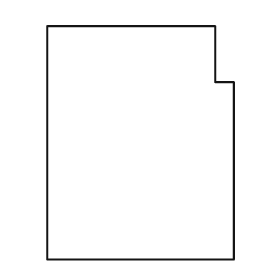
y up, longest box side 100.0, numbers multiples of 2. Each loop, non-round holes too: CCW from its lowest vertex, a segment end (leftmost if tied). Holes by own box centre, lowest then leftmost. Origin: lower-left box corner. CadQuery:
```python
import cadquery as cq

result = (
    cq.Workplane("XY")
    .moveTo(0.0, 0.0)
    .lineTo(80.0, 0.0)
    .lineTo(80.0, 76.0)
    .lineTo(72.0, 76.0)
    .lineTo(72.0, 100.0)
    .lineTo(0.0, 100.0)
    .close()
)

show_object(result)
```